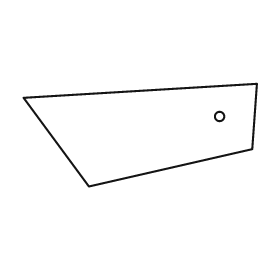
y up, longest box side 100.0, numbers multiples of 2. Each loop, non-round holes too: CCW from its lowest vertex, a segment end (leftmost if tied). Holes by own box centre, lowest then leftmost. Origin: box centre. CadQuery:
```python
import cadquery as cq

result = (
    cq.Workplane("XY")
    .moveTo(-22.0, -22.0)
    .lineTo(48.0, -6.0)
    .lineTo(50.0, 22.0)
    .lineTo(-50.0, 16.0)
    .close()
    .moveTo(34.0, 8.0)
    .circle(2.0)
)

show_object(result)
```